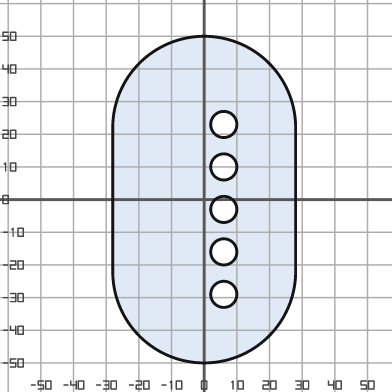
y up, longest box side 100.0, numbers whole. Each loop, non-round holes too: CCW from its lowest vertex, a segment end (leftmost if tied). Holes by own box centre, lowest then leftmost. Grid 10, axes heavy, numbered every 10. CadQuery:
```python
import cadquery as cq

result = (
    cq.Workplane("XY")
    .moveTo(-28.0, -22.0)
    .threePointArc((0.0, -50.0), (28.0, -22.0))
    .lineTo(28.0, 22.0)
    .threePointArc((0.0, 50.0), (-28.0, 22.0))
    .close()
    .moveTo(6.0, -29.0)
    .circle(4.0)
    .moveTo(6.0, -16.0)
    .circle(4.0)
    .moveTo(6.0, -3.0)
    .circle(4.0)
    .moveTo(6.0, 10.0)
    .circle(4.0)
    .moveTo(6.0, 23.0)
    .circle(4.0)
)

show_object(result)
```